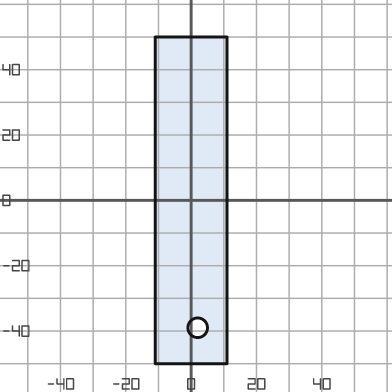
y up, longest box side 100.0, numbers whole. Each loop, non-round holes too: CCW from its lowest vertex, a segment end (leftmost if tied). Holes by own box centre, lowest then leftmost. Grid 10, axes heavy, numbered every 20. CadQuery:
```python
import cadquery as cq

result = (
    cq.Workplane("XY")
    .moveTo(-11.0, -50.0)
    .lineTo(11.0, -50.0)
    .lineTo(11.0, 50.0)
    .lineTo(-11.0, 50.0)
    .close()
    .moveTo(2.0, -39.0)
    .circle(3.0)
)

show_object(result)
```